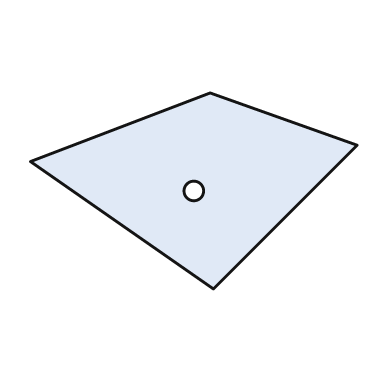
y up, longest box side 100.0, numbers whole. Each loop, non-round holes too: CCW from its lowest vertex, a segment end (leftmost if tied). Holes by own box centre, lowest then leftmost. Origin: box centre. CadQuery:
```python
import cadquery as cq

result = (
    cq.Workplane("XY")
    .moveTo(6.0, -30.0)
    .lineTo(50.0, 14.0)
    .lineTo(5.0, 30.0)
    .lineTo(-50.0, 9.0)
    .close()
    .moveTo(0.0, 0.0)
    .circle(3.0)
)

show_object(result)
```